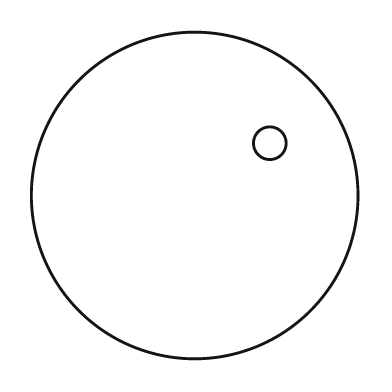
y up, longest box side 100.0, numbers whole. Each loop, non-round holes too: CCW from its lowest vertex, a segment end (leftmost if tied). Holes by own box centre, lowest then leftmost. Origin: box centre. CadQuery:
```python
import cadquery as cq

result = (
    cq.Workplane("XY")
    .moveTo(0.0, 0.0)
    .circle(50.0)
    .moveTo(23.0, 16.0)
    .circle(5.0)
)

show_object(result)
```